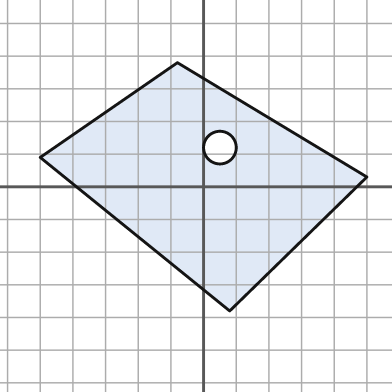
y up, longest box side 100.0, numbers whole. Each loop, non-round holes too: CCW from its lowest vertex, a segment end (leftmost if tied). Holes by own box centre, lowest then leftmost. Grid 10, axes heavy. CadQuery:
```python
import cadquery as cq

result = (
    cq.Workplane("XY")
    .moveTo(8.0, -38.0)
    .lineTo(50.0, 3.0)
    .lineTo(-8.0, 38.0)
    .lineTo(-50.0, 9.0)
    .close()
    .moveTo(5.0, 12.0)
    .circle(5.0)
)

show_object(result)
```